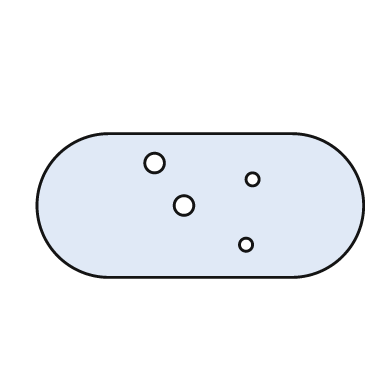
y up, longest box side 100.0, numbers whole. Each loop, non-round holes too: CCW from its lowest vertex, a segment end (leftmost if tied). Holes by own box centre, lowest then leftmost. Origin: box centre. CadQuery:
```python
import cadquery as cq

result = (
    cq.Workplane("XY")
    .moveTo(-28.0, -22.0)
    .lineTo(28.0, -22.0)
    .threePointArc((50.0, 0.0), (28.0, 22.0))
    .lineTo(-28.0, 22.0)
    .threePointArc((-50.0, 0.0), (-28.0, -22.0))
    .close()
    .moveTo(14.0, -12.0)
    .circle(2.0)
    .moveTo(-5.0, 0.0)
    .circle(3.0)
    .moveTo(16.0, 8.0)
    .circle(2.0)
    .moveTo(-14.0, 13.0)
    .circle(3.0)
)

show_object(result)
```